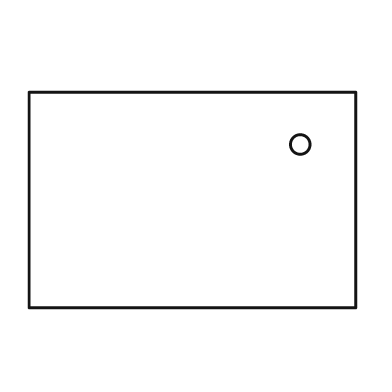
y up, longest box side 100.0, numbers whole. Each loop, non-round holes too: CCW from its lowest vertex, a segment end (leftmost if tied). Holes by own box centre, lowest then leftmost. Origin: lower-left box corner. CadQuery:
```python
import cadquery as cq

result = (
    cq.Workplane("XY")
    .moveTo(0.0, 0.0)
    .lineTo(100.0, 0.0)
    .lineTo(100.0, 66.0)
    .lineTo(0.0, 66.0)
    .close()
    .moveTo(83.0, 50.0)
    .circle(3.0)
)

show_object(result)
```